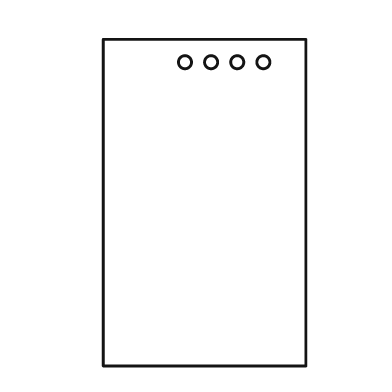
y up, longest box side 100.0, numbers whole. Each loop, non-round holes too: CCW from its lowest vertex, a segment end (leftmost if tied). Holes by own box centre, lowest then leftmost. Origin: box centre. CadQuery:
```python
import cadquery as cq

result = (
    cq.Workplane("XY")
    .moveTo(-31.0, -50.0)
    .lineTo(31.0, -50.0)
    .lineTo(31.0, 50.0)
    .lineTo(-31.0, 50.0)
    .close()
    .moveTo(-6.0, 43.0)
    .circle(2.0)
    .moveTo(2.0, 43.0)
    .circle(2.0)
    .moveTo(10.0, 43.0)
    .circle(2.0)
    .moveTo(18.0, 43.0)
    .circle(2.0)
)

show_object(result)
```